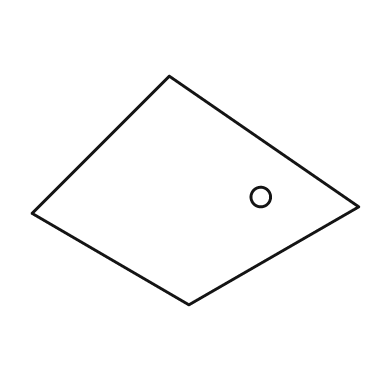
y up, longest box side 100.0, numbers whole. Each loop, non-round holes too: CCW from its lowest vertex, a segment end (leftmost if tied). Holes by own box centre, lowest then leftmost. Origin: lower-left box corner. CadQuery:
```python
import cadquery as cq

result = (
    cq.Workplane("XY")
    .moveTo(48.0, 0.0)
    .lineTo(100.0, 30.0)
    .lineTo(42.0, 70.0)
    .lineTo(0.0, 28.0)
    .close()
    .moveTo(70.0, 33.0)
    .circle(3.0)
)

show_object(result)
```